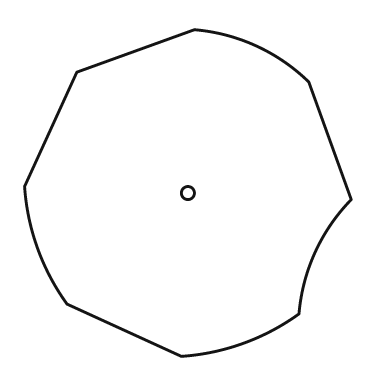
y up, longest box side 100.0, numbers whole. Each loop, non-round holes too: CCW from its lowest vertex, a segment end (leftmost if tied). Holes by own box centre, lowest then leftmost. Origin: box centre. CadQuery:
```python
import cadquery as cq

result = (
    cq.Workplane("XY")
    .moveTo(-2.0, -50.0)
    .threePointArc((17.0, -46.0), (34.0, -37.0))
    .threePointArc((39.0, -18.0), (50.0, -2.0))
    .lineTo(37.0, 34.0)
    .threePointArc((21.0, 45.0), (2.0, 50.0))
    .lineTo(-34.0, 37.0)
    .lineTo(-50.0, 2.0)
    .threePointArc((-46.0, -17.0), (-37.0, -34.0))
    .close()
    .moveTo(0.0, 0.0)
    .circle(2.0)
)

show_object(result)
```